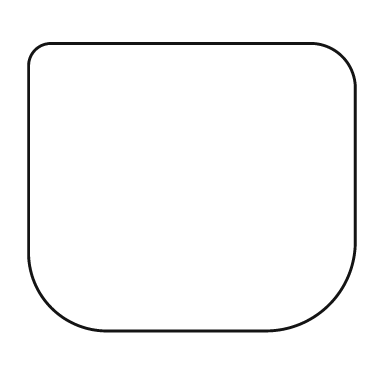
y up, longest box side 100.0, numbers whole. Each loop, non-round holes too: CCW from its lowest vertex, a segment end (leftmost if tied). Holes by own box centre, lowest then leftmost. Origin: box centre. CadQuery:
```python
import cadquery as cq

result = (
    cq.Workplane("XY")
    .moveTo(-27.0, -44.0)
    .lineTo(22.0, -44.0)
    .threePointArc((42.0, -36.0), (50.0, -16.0))
    .lineTo(50.0, 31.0)
    .threePointArc((46.0, 40.0), (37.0, 44.0))
    .lineTo(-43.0, 44.0)
    .threePointArc((-48.0, 42.0), (-50.0, 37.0))
    .lineTo(-50.0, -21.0)
    .threePointArc((-43.0, -37.0), (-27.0, -44.0))
    .close()
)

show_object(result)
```